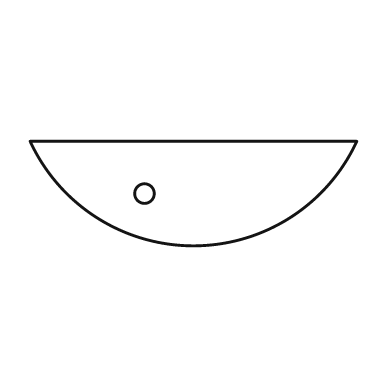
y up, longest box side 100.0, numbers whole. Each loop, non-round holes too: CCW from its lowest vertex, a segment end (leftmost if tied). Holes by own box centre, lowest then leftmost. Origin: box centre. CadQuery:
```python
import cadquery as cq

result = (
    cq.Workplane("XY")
    .moveTo(-50.0, 16.0)
    .threePointArc((0.0, -16.0), (50.0, 16.0))
    .close()
    .moveTo(-15.0, 0.0)
    .circle(3.0)
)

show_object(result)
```